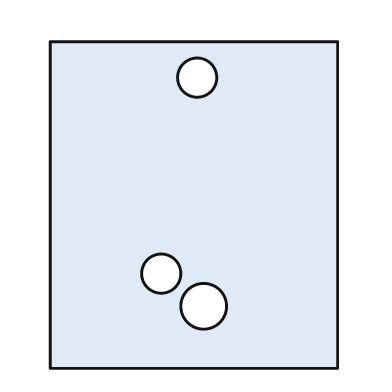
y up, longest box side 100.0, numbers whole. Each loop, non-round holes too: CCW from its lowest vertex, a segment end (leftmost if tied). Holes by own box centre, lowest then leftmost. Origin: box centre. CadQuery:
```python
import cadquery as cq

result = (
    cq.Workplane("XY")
    .moveTo(-44.0, -50.0)
    .lineTo(44.0, -50.0)
    .lineTo(44.0, 50.0)
    .lineTo(-44.0, 50.0)
    .close()
    .moveTo(3.0, -31.0)
    .circle(7.0)
    .moveTo(-10.0, -21.0)
    .circle(6.0)
    .moveTo(1.0, 39.0)
    .circle(6.0)
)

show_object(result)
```